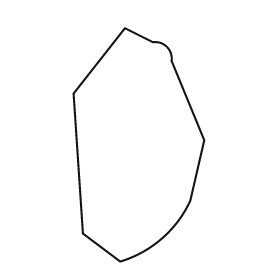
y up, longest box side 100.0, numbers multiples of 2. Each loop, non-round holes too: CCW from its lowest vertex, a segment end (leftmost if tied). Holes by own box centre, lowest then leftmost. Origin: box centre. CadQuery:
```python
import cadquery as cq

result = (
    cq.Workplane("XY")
    .moveTo(-8.0, -50.0)
    .threePointArc((10.0, -40.0), (22.0, -24.0))
    .lineTo(28.0, 2.0)
    .lineTo(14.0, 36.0)
    .threePointArc((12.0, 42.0), (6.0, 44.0))
    .lineTo(-6.0, 50.0)
    .lineTo(-28.0, 22.0)
    .lineTo(-24.0, -38.0)
    .close()
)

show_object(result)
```